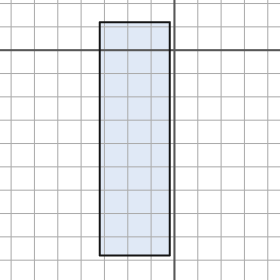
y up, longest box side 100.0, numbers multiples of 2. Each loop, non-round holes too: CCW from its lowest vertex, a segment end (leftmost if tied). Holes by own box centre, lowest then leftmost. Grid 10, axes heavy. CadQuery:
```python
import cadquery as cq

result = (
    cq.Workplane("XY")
    .moveTo(-32.0, -88.0)
    .lineTo(-2.0, -88.0)
    .lineTo(-2.0, 12.0)
    .lineTo(-32.0, 12.0)
    .close()
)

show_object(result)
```